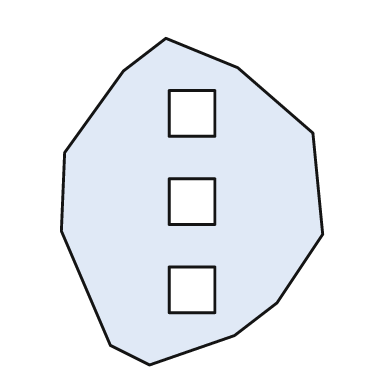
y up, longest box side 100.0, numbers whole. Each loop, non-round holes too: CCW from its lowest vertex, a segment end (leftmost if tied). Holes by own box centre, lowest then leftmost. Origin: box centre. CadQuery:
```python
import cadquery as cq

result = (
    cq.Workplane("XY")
    .moveTo(-13.0, -50.0)
    .lineTo(13.0, -41.0)
    .lineTo(26.0, -31.0)
    .lineTo(40.0, -10.0)
    .lineTo(37.0, 21.0)
    .lineTo(14.0, 41.0)
    .lineTo(-8.0, 50.0)
    .lineTo(-21.0, 40.0)
    .lineTo(-39.0, 15.0)
    .lineTo(-40.0, -9.0)
    .lineTo(-25.0, -44.0)
    .close()
    .moveTo(-7.0, -34.0)
    .lineTo(7.0, -34.0)
    .lineTo(7.0, -20.0)
    .lineTo(-7.0, -20.0)
    .close()
    .moveTo(-7.0, -7.0)
    .lineTo(7.0, -7.0)
    .lineTo(7.0, 7.0)
    .lineTo(-7.0, 7.0)
    .close()
    .moveTo(-7.0, 20.0)
    .lineTo(7.0, 20.0)
    .lineTo(7.0, 34.0)
    .lineTo(-7.0, 34.0)
    .close()
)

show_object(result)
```